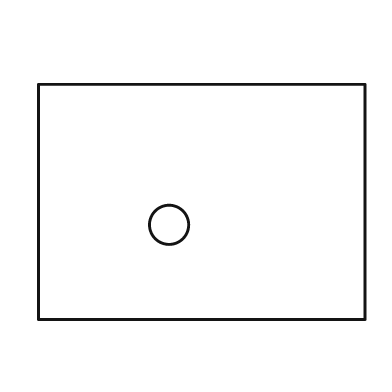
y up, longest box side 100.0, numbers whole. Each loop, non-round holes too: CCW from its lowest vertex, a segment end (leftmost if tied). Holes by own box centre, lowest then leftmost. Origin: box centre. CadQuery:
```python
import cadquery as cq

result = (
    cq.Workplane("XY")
    .moveTo(-50.0, -36.0)
    .lineTo(50.0, -36.0)
    .lineTo(50.0, 36.0)
    .lineTo(-50.0, 36.0)
    .close()
    .moveTo(-10.0, -7.0)
    .circle(6.0)
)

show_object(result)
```